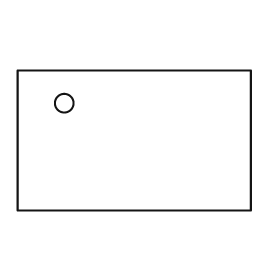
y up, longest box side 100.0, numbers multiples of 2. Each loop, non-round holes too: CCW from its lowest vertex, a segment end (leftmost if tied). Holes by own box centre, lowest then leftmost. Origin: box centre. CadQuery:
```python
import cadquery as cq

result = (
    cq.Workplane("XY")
    .moveTo(-50.0, -30.0)
    .lineTo(50.0, -30.0)
    .lineTo(50.0, 30.0)
    .lineTo(-50.0, 30.0)
    .close()
    .moveTo(-30.0, 16.0)
    .circle(4.0)
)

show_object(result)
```